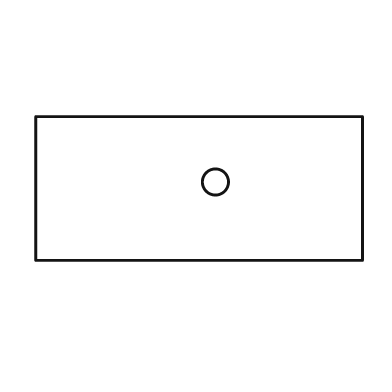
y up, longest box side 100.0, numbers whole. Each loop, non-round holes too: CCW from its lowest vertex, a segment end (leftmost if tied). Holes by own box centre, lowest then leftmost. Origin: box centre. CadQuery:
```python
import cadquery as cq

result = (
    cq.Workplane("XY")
    .moveTo(-50.0, -22.0)
    .lineTo(50.0, -22.0)
    .lineTo(50.0, 22.0)
    .lineTo(-50.0, 22.0)
    .close()
    .moveTo(5.0, 2.0)
    .circle(4.0)
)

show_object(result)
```